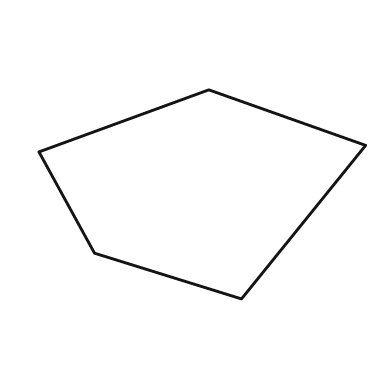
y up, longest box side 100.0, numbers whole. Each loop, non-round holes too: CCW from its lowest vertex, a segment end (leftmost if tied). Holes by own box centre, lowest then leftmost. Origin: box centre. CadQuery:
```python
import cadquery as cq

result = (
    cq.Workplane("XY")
    .moveTo(12.0, -32.0)
    .lineTo(50.0, 15.0)
    .lineTo(2.0, 32.0)
    .lineTo(-50.0, 13.0)
    .lineTo(-33.0, -18.0)
    .close()
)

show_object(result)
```